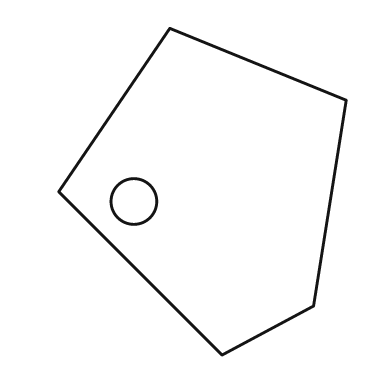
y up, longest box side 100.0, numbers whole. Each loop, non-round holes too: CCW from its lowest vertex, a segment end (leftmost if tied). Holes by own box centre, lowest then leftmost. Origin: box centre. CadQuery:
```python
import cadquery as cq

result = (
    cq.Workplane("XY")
    .moveTo(6.0, -50.0)
    .lineTo(34.0, -35.0)
    .lineTo(44.0, 28.0)
    .lineTo(-10.0, 50.0)
    .lineTo(-44.0, 0.0)
    .close()
    .moveTo(-21.0, -3.0)
    .circle(7.0)
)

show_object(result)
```